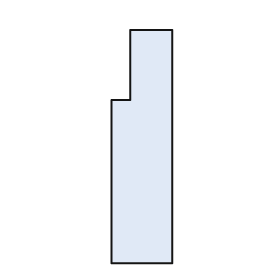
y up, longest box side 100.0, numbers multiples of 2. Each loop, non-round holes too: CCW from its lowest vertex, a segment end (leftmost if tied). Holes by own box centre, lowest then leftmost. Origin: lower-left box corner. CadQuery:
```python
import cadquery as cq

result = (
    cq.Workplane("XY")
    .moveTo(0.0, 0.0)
    .lineTo(26.0, 0.0)
    .lineTo(26.0, 100.0)
    .lineTo(8.0, 100.0)
    .lineTo(8.0, 70.0)
    .lineTo(0.0, 70.0)
    .close()
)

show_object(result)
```